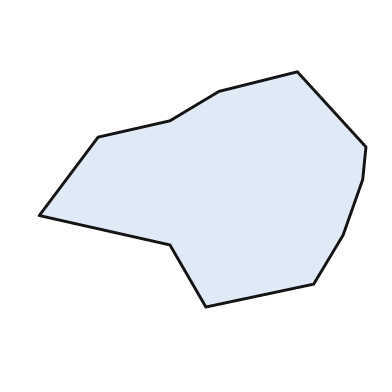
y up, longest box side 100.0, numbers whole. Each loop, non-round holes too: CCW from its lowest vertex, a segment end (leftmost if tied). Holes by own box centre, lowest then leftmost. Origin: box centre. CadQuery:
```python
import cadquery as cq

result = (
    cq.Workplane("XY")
    .moveTo(1.0, -36.0)
    .lineTo(34.0, -29.0)
    .lineTo(43.0, -14.0)
    .lineTo(49.0, 3.0)
    .lineTo(50.0, 13.0)
    .lineTo(29.0, 36.0)
    .lineTo(5.0, 30.0)
    .lineTo(-10.0, 21.0)
    .lineTo(-32.0, 16.0)
    .lineTo(-50.0, -8.0)
    .lineTo(-10.0, -17.0)
    .close()
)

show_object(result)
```